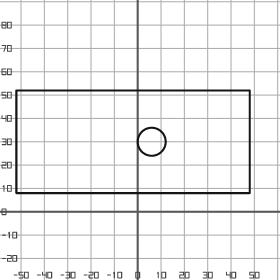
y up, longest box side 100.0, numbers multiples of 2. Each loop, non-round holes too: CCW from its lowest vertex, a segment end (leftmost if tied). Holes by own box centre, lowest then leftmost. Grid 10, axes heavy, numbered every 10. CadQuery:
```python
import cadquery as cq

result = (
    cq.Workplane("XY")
    .moveTo(-52.0, 8.0)
    .lineTo(48.0, 8.0)
    .lineTo(48.0, 52.0)
    .lineTo(-52.0, 52.0)
    .close()
    .moveTo(6.0, 30.0)
    .circle(6.0)
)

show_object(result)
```